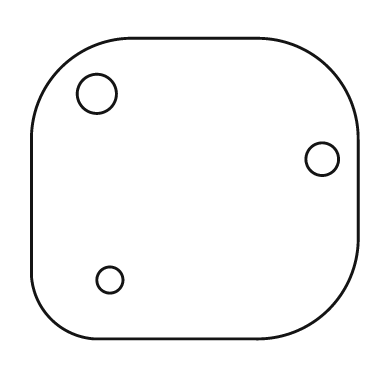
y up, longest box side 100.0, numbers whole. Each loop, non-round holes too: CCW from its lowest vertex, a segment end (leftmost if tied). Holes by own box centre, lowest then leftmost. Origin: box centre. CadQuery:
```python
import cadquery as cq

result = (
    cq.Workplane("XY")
    .moveTo(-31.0, -46.0)
    .lineTo(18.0, -46.0)
    .threePointArc((41.0, -37.0), (50.0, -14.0))
    .lineTo(50.0, 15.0)
    .threePointArc((41.0, 37.0), (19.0, 46.0))
    .lineTo(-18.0, 46.0)
    .threePointArc((-41.0, 37.0), (-50.0, 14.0))
    .lineTo(-50.0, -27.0)
    .threePointArc((-44.0, -40.0), (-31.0, -46.0))
    .close()
    .moveTo(-26.0, -28.0)
    .circle(4.0)
    .moveTo(39.0, 9.0)
    .circle(5.0)
    .moveTo(-30.0, 29.0)
    .circle(6.0)
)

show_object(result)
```